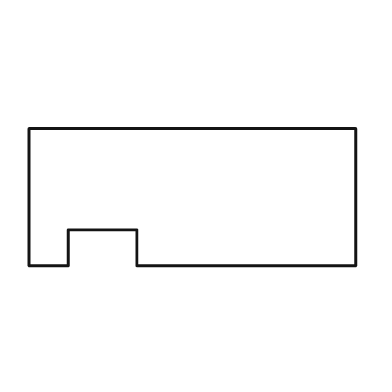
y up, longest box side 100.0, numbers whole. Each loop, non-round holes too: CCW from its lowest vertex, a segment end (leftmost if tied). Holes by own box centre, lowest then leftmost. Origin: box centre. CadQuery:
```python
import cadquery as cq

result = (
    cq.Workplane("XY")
    .moveTo(-50.0, -21.0)
    .lineTo(-38.0, -21.0)
    .lineTo(-38.0, -10.0)
    .lineTo(-17.0, -10.0)
    .lineTo(-17.0, -21.0)
    .lineTo(50.0, -21.0)
    .lineTo(50.0, 21.0)
    .lineTo(-50.0, 21.0)
    .close()
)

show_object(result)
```